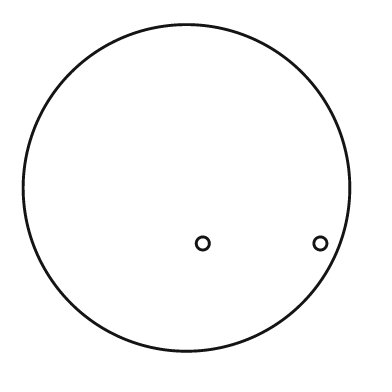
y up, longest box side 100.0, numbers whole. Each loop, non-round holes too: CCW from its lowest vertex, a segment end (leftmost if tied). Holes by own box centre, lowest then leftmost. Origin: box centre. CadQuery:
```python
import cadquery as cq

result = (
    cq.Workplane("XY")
    .moveTo(0.0, 0.0)
    .circle(50.0)
    .moveTo(5.0, -17.0)
    .circle(2.0)
    .moveTo(41.0, -17.0)
    .circle(2.0)
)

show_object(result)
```